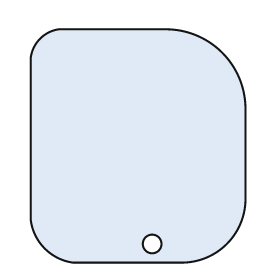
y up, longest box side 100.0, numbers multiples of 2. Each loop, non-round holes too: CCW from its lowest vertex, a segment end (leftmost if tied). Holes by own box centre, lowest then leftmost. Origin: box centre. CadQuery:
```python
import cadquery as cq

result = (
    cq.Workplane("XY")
    .moveTo(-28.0, -50.0)
    .lineTo(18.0, -50.0)
    .threePointArc((38.0, -42.0), (46.0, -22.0))
    .lineTo(46.0, 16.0)
    .threePointArc((36.0, 40.0), (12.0, 50.0))
    .lineTo(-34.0, 50.0)
    .threePointArc((-42.0, 46.0), (-46.0, 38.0))
    .lineTo(-46.0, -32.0)
    .threePointArc((-40.0, -44.0), (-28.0, -50.0))
    .close()
    .moveTo(6.0, -42.0)
    .circle(4.0)
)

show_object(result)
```